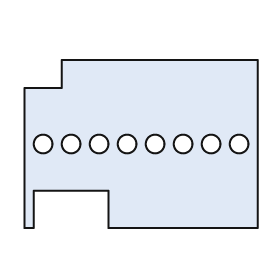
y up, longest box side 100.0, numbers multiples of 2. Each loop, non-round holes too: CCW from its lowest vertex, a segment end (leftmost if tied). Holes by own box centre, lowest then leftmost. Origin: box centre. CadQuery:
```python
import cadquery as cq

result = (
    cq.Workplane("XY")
    .moveTo(-50.0, -36.0)
    .lineTo(-46.0, -36.0)
    .lineTo(-46.0, -20.0)
    .lineTo(-14.0, -20.0)
    .lineTo(-14.0, -36.0)
    .lineTo(50.0, -36.0)
    .lineTo(50.0, 36.0)
    .lineTo(-34.0, 36.0)
    .lineTo(-34.0, 24.0)
    .lineTo(-50.0, 24.0)
    .close()
    .moveTo(-42.0, 0.0)
    .circle(4.0)
    .moveTo(-30.0, 0.0)
    .circle(4.0)
    .moveTo(-18.0, 0.0)
    .circle(4.0)
    .moveTo(-6.0, 0.0)
    .circle(4.0)
    .moveTo(6.0, 0.0)
    .circle(4.0)
    .moveTo(18.0, 0.0)
    .circle(4.0)
    .moveTo(30.0, 0.0)
    .circle(4.0)
    .moveTo(42.0, 0.0)
    .circle(4.0)
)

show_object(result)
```